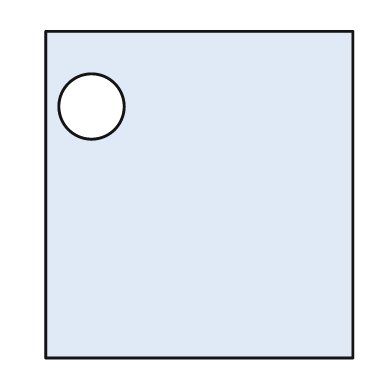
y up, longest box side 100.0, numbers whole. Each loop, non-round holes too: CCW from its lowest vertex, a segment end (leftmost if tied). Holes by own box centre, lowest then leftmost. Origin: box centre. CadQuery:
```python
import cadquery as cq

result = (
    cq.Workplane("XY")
    .moveTo(-47.0, -50.0)
    .lineTo(47.0, -50.0)
    .lineTo(47.0, 50.0)
    .lineTo(-47.0, 50.0)
    .close()
    .moveTo(-33.0, 27.0)
    .circle(10.0)
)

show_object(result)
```